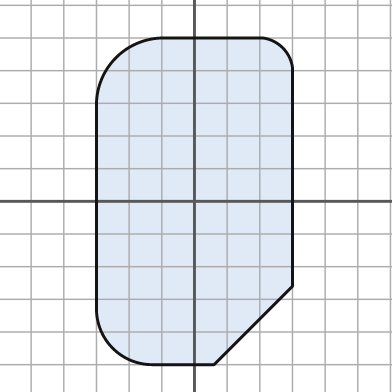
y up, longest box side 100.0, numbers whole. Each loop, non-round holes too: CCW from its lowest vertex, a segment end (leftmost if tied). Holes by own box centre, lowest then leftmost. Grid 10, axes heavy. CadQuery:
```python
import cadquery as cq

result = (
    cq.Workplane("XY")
    .moveTo(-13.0, -50.0)
    .lineTo(6.0, -50.0)
    .lineTo(30.0, -26.0)
    .lineTo(30.0, 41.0)
    .threePointArc((27.0, 47.0), (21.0, 50.0))
    .lineTo(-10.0, 50.0)
    .threePointArc((-24.0, 44.0), (-30.0, 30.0))
    .lineTo(-30.0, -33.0)
    .threePointArc((-25.0, -45.0), (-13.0, -50.0))
    .close()
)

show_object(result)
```